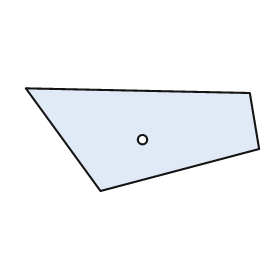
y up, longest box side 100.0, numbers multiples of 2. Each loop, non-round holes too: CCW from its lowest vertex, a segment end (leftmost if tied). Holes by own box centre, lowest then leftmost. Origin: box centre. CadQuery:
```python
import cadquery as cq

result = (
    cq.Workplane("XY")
    .moveTo(-18.0, -22.0)
    .lineTo(50.0, -4.0)
    .lineTo(46.0, 20.0)
    .lineTo(-50.0, 22.0)
    .close()
    .moveTo(0.0, 0.0)
    .circle(2.0)
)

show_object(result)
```